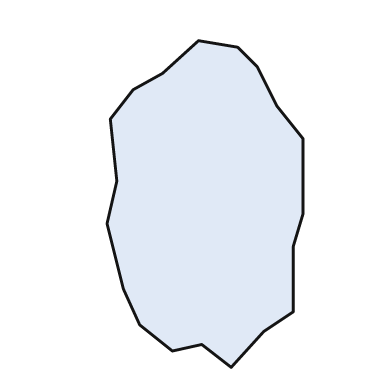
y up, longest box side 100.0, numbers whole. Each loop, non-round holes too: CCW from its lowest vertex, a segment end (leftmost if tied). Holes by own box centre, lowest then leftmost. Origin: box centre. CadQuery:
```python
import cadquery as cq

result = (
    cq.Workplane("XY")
    .moveTo(8.0, -50.0)
    .lineTo(18.0, -39.0)
    .lineTo(27.0, -33.0)
    .lineTo(27.0, -13.0)
    .lineTo(30.0, -3.0)
    .lineTo(30.0, 20.0)
    .lineTo(22.0, 30.0)
    .lineTo(16.0, 42.0)
    .lineTo(10.0, 48.0)
    .lineTo(-2.0, 50.0)
    .lineTo(-13.0, 40.0)
    .lineTo(-22.0, 35.0)
    .lineTo(-29.0, 26.0)
    .lineTo(-27.0, 7.0)
    .lineTo(-30.0, -6.0)
    .lineTo(-25.0, -26.0)
    .lineTo(-20.0, -37.0)
    .lineTo(-10.0, -45.0)
    .lineTo(-1.0, -43.0)
    .close()
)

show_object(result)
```